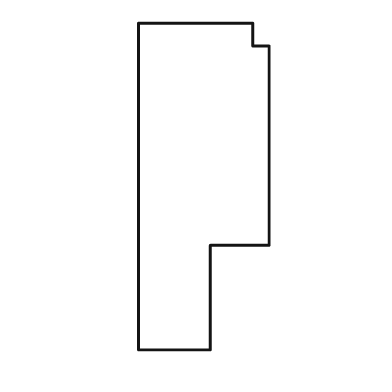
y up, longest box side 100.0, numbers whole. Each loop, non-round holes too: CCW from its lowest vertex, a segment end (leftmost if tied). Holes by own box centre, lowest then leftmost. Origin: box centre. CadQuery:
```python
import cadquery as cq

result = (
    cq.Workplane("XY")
    .moveTo(-20.0, -50.0)
    .lineTo(2.0, -50.0)
    .lineTo(2.0, -18.0)
    .lineTo(20.0, -18.0)
    .lineTo(20.0, 43.0)
    .lineTo(15.0, 43.0)
    .lineTo(15.0, 50.0)
    .lineTo(-20.0, 50.0)
    .close()
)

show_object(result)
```